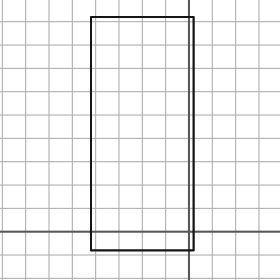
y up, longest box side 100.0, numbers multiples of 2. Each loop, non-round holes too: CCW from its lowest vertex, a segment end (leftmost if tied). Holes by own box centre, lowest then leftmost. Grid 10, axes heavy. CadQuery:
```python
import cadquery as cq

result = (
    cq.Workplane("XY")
    .moveTo(-42.0, -8.0)
    .lineTo(2.0, -8.0)
    .lineTo(2.0, 92.0)
    .lineTo(-42.0, 92.0)
    .close()
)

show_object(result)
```